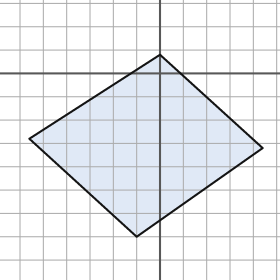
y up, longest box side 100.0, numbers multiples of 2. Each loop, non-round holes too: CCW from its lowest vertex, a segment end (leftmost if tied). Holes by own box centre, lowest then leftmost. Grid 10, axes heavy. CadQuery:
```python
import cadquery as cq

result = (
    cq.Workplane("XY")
    .moveTo(-10.0, -70.0)
    .lineTo(44.0, -32.0)
    .lineTo(0.0, 8.0)
    .lineTo(-56.0, -28.0)
    .close()
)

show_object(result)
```